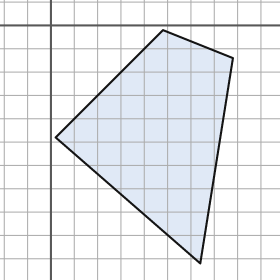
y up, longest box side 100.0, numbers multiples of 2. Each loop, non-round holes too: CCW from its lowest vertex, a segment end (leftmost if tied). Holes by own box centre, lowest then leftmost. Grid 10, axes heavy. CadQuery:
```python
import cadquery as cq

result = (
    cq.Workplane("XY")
    .moveTo(64.0, -102.0)
    .lineTo(78.0, -14.0)
    .lineTo(48.0, -2.0)
    .lineTo(2.0, -48.0)
    .close()
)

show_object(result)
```